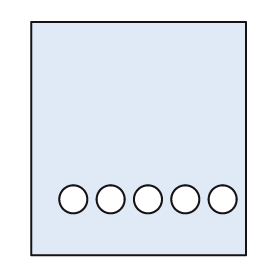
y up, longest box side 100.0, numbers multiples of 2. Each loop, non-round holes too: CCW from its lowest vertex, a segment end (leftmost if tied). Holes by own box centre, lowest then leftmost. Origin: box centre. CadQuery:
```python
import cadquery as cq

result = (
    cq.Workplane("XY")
    .moveTo(-46.0, -50.0)
    .lineTo(46.0, -50.0)
    .lineTo(46.0, 50.0)
    .lineTo(-46.0, 50.0)
    .close()
    .moveTo(-28.0, -26.0)
    .circle(6.0)
    .moveTo(-12.0, -26.0)
    .circle(6.0)
    .moveTo(4.0, -26.0)
    .circle(6.0)
    .moveTo(20.0, -26.0)
    .circle(6.0)
    .moveTo(36.0, -26.0)
    .circle(6.0)
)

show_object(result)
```